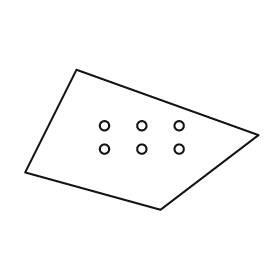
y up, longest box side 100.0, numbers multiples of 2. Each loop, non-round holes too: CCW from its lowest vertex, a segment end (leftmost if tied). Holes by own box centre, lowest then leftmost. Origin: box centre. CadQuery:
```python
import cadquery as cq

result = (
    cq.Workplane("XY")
    .moveTo(8.0, -30.0)
    .lineTo(50.0, 2.0)
    .lineTo(-28.0, 30.0)
    .lineTo(-50.0, -14.0)
    .close()
    .moveTo(-16.0, -4.0)
    .circle(2.0)
    .moveTo(0.0, -4.0)
    .circle(2.0)
    .moveTo(16.0, -4.0)
    .circle(2.0)
    .moveTo(-16.0, 6.0)
    .circle(2.0)
    .moveTo(0.0, 6.0)
    .circle(2.0)
    .moveTo(16.0, 6.0)
    .circle(2.0)
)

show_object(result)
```